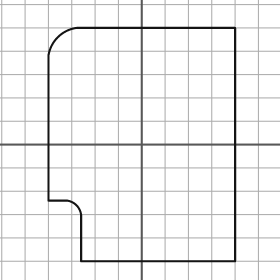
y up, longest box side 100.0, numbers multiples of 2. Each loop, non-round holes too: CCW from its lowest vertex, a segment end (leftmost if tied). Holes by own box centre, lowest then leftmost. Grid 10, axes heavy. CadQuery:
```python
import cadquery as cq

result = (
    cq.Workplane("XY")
    .moveTo(-26.0, -50.0)
    .lineTo(40.0, -50.0)
    .lineTo(40.0, 50.0)
    .lineTo(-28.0, 50.0)
    .threePointArc((-36.0, 46.0), (-40.0, 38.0))
    .lineTo(-40.0, -24.0)
    .lineTo(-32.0, -24.0)
    .threePointArc((-28.0, -26.0), (-26.0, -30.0))
    .close()
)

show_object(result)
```